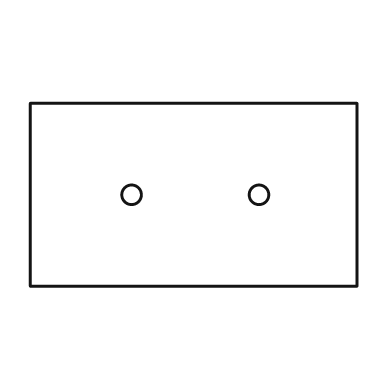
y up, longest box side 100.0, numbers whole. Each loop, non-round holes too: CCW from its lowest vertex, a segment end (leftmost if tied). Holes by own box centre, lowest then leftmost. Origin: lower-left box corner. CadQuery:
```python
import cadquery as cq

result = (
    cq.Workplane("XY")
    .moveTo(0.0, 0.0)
    .lineTo(100.0, 0.0)
    .lineTo(100.0, 56.0)
    .lineTo(0.0, 56.0)
    .close()
    .moveTo(31.0, 28.0)
    .circle(3.0)
    .moveTo(70.0, 28.0)
    .circle(3.0)
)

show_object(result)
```